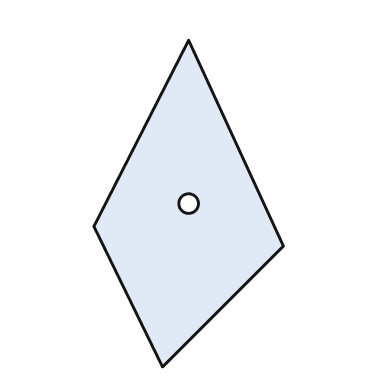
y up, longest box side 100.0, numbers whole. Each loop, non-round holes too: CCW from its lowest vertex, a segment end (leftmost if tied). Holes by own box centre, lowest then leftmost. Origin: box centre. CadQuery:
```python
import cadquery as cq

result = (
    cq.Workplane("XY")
    .moveTo(-8.0, -50.0)
    .lineTo(29.0, -13.0)
    .lineTo(0.0, 50.0)
    .lineTo(-29.0, -7.0)
    .close()
    .moveTo(0.0, 0.0)
    .circle(3.0)
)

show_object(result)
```